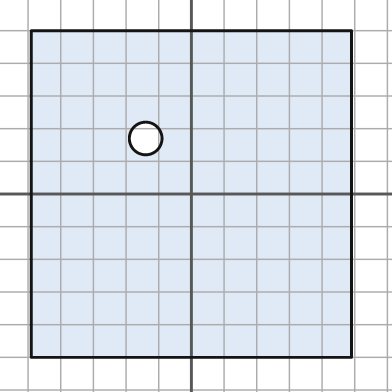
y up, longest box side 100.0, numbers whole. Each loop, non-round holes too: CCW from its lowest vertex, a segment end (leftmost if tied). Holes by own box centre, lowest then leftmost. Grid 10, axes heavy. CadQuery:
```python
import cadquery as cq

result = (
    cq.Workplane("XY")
    .moveTo(-49.0, -50.0)
    .lineTo(49.0, -50.0)
    .lineTo(49.0, 50.0)
    .lineTo(-49.0, 50.0)
    .close()
    .moveTo(-14.0, 17.0)
    .circle(5.0)
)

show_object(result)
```